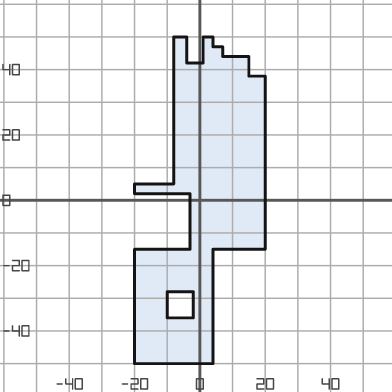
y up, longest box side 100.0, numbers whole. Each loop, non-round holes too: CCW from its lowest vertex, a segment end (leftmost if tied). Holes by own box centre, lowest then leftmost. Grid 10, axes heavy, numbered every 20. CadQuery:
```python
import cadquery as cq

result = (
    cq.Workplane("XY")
    .moveTo(-20.0, -50.0)
    .lineTo(4.0, -50.0)
    .lineTo(4.0, -15.0)
    .lineTo(20.0, -15.0)
    .lineTo(20.0, 38.0)
    .lineTo(15.0, 38.0)
    .lineTo(15.0, 44.0)
    .lineTo(7.0, 44.0)
    .lineTo(7.0, 47.0)
    .lineTo(4.0, 47.0)
    .lineTo(4.0, 50.0)
    .lineTo(1.0, 50.0)
    .lineTo(1.0, 42.0)
    .lineTo(-4.0, 42.0)
    .lineTo(-4.0, 50.0)
    .lineTo(-8.0, 50.0)
    .lineTo(-8.0, 5.0)
    .lineTo(-20.0, 5.0)
    .lineTo(-20.0, 2.0)
    .lineTo(-3.0, 2.0)
    .lineTo(-3.0, -15.0)
    .lineTo(-20.0, -15.0)
    .close()
    .moveTo(-10.0, -36.0)
    .lineTo(-2.0, -36.0)
    .lineTo(-2.0, -28.0)
    .lineTo(-10.0, -28.0)
    .close()
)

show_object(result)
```